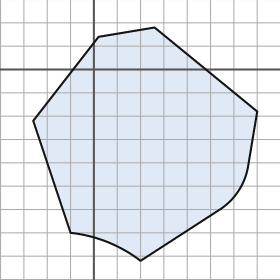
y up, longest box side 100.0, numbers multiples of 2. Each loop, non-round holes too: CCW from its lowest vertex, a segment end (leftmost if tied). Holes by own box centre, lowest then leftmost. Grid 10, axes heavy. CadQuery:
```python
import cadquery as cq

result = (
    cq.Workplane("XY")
    .moveTo(20.0, -82.0)
    .lineTo(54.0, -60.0)
    .threePointArc((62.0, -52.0), (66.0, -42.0))
    .lineTo(70.0, -18.0)
    .lineTo(26.0, 18.0)
    .lineTo(2.0, 14.0)
    .lineTo(-26.0, -22.0)
    .lineTo(-10.0, -70.0)
    .threePointArc((6.0, -74.0), (20.0, -82.0))
    .close()
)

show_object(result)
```